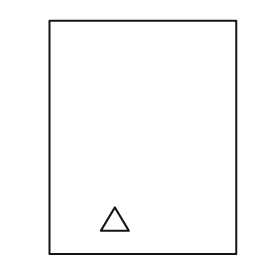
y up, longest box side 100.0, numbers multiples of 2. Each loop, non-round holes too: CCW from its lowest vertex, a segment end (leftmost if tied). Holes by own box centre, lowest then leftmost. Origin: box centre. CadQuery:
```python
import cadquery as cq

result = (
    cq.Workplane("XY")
    .moveTo(-40.0, -50.0)
    .lineTo(40.0, -50.0)
    .lineTo(40.0, 50.0)
    .lineTo(-40.0, 50.0)
    .close()
    .moveTo(-18.0, -40.0)
    .lineTo(-6.0, -40.0)
    .lineTo(-12.0, -30.0)
    .close()
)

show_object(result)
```